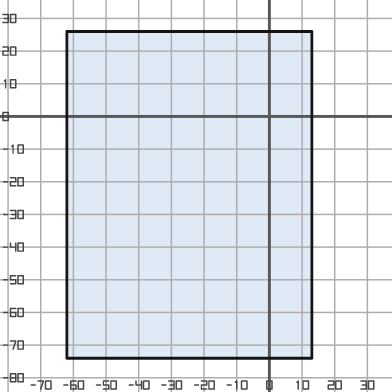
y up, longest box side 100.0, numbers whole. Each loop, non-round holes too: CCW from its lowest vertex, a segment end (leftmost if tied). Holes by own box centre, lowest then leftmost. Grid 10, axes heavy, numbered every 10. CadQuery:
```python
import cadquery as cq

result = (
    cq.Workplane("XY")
    .moveTo(-62.0, -74.0)
    .lineTo(13.0, -74.0)
    .lineTo(13.0, 26.0)
    .lineTo(-62.0, 26.0)
    .close()
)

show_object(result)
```